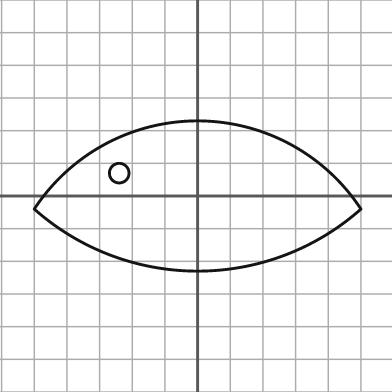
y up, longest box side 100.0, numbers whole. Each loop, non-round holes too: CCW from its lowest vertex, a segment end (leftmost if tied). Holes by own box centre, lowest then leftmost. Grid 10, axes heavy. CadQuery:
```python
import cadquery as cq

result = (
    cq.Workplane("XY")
    .moveTo(-50.0, -4.0)
    .threePointArc((0.0, -23.0), (50.0, -4.0))
    .threePointArc((0.0, 23.0), (-50.0, -4.0))
    .close()
    .moveTo(-24.0, 7.0)
    .circle(3.0)
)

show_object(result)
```